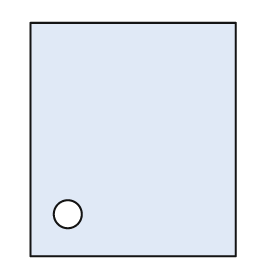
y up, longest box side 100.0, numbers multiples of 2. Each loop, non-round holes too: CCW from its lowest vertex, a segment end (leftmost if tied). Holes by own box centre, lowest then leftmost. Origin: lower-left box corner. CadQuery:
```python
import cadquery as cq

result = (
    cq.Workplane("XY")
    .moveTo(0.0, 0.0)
    .lineTo(88.0, 0.0)
    .lineTo(88.0, 100.0)
    .lineTo(0.0, 100.0)
    .close()
    .moveTo(16.0, 18.0)
    .circle(6.0)
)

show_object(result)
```